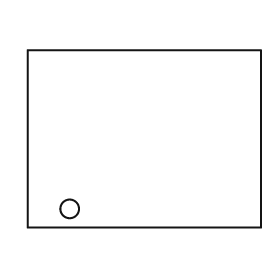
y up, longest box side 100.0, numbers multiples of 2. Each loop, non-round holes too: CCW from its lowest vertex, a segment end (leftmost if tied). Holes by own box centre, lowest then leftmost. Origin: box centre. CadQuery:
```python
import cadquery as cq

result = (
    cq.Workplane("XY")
    .moveTo(-50.0, -38.0)
    .lineTo(50.0, -38.0)
    .lineTo(50.0, 38.0)
    .lineTo(-50.0, 38.0)
    .close()
    .moveTo(-32.0, -30.0)
    .circle(4.0)
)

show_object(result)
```